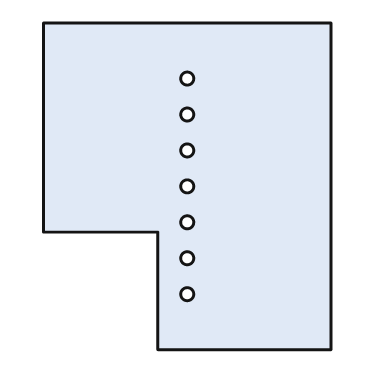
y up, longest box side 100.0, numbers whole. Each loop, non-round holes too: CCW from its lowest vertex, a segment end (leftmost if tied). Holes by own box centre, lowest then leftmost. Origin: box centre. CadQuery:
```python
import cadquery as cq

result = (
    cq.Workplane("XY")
    .moveTo(-9.0, -50.0)
    .lineTo(44.0, -50.0)
    .lineTo(44.0, 50.0)
    .lineTo(-44.0, 50.0)
    .lineTo(-44.0, -14.0)
    .lineTo(-9.0, -14.0)
    .close()
    .moveTo(0.0, -33.0)
    .circle(2.0)
    .moveTo(0.0, -22.0)
    .circle(2.0)
    .moveTo(0.0, -11.0)
    .circle(2.0)
    .moveTo(0.0, 0.0)
    .circle(2.0)
    .moveTo(0.0, 11.0)
    .circle(2.0)
    .moveTo(0.0, 22.0)
    .circle(2.0)
    .moveTo(0.0, 33.0)
    .circle(2.0)
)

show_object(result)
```